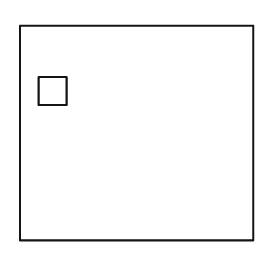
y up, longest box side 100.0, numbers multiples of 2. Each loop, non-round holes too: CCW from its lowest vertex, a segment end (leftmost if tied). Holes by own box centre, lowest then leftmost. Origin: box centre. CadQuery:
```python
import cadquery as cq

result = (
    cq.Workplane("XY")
    .moveTo(-50.0, -46.0)
    .lineTo(50.0, -46.0)
    .lineTo(50.0, 46.0)
    .lineTo(-50.0, 46.0)
    .close()
    .moveTo(-42.0, 12.0)
    .lineTo(-30.0, 12.0)
    .lineTo(-30.0, 24.0)
    .lineTo(-42.0, 24.0)
    .close()
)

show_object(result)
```